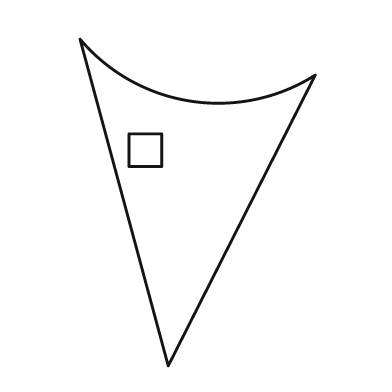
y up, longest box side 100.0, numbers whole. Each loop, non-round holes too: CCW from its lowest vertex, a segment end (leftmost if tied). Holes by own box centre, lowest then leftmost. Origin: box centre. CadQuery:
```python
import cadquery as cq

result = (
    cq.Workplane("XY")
    .moveTo(-9.0, -50.0)
    .lineTo(36.0, 39.0)
    .threePointArc((-2.0, 31.0), (-36.0, 50.0))
    .close()
    .moveTo(-21.0, 11.0)
    .lineTo(-11.0, 11.0)
    .lineTo(-11.0, 21.0)
    .lineTo(-21.0, 21.0)
    .close()
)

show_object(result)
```